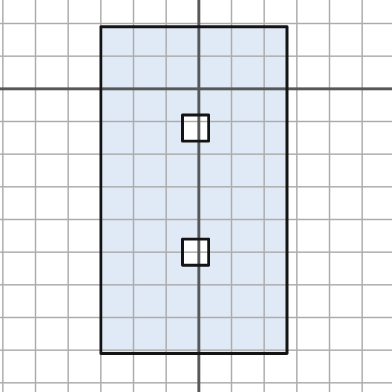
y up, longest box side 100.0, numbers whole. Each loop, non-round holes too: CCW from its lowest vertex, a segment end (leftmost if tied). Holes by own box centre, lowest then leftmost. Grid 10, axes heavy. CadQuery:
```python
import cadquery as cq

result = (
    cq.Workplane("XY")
    .moveTo(-30.0, -81.0)
    .lineTo(27.0, -81.0)
    .lineTo(27.0, 19.0)
    .lineTo(-30.0, 19.0)
    .close()
    .moveTo(-5.0, -54.0)
    .lineTo(3.0, -54.0)
    .lineTo(3.0, -46.0)
    .lineTo(-5.0, -46.0)
    .close()
    .moveTo(-5.0, -16.0)
    .lineTo(3.0, -16.0)
    .lineTo(3.0, -8.0)
    .lineTo(-5.0, -8.0)
    .close()
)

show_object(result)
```